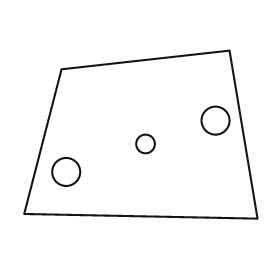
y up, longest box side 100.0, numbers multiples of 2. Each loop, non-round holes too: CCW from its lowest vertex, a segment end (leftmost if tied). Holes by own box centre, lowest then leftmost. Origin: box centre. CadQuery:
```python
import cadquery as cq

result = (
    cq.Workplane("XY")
    .moveTo(50.0, -36.0)
    .lineTo(38.0, 36.0)
    .lineTo(-34.0, 28.0)
    .lineTo(-50.0, -34.0)
    .close()
    .moveTo(-32.0, -16.0)
    .circle(6.0)
    .moveTo(2.0, -4.0)
    .circle(4.0)
    .moveTo(32.0, 6.0)
    .circle(6.0)
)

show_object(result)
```